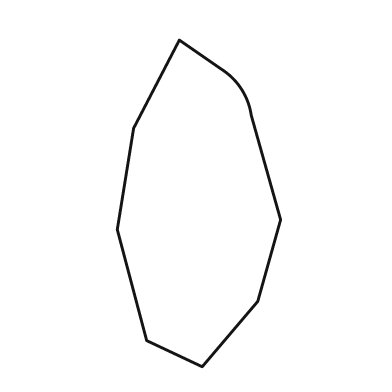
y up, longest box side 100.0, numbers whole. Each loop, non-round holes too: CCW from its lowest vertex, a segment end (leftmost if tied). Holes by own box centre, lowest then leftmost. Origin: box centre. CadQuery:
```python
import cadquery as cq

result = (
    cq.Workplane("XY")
    .moveTo(1.0, -50.0)
    .lineTo(18.0, -30.0)
    .lineTo(25.0, -5.0)
    .lineTo(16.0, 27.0)
    .threePointArc((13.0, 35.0), (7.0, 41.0))
    .lineTo(-6.0, 50.0)
    .lineTo(-20.0, 23.0)
    .lineTo(-25.0, -8.0)
    .lineTo(-16.0, -42.0)
    .close()
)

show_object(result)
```